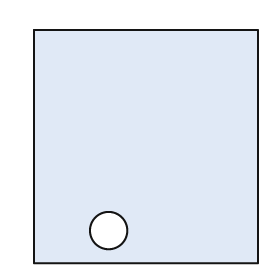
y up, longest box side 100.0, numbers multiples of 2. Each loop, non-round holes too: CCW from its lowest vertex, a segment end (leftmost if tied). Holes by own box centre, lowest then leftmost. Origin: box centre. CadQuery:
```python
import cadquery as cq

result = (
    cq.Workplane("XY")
    .moveTo(-48.0, -50.0)
    .lineTo(48.0, -50.0)
    .lineTo(48.0, 50.0)
    .lineTo(-48.0, 50.0)
    .close()
    .moveTo(-16.0, -36.0)
    .circle(8.0)
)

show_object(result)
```